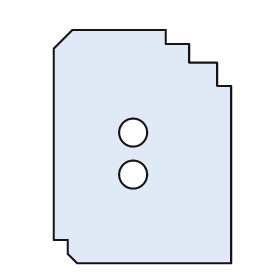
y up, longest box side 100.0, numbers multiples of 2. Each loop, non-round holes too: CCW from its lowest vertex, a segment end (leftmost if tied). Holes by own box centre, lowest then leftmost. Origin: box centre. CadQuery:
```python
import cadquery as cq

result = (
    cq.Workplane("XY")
    .moveTo(-28.0, -50.0)
    .lineTo(38.0, -50.0)
    .lineTo(38.0, 26.0)
    .lineTo(32.0, 26.0)
    .lineTo(32.0, 36.0)
    .lineTo(20.0, 36.0)
    .lineTo(20.0, 44.0)
    .lineTo(10.0, 44.0)
    .lineTo(10.0, 50.0)
    .lineTo(-30.0, 50.0)
    .lineTo(-38.0, 42.0)
    .lineTo(-38.0, -40.0)
    .lineTo(-32.0, -40.0)
    .lineTo(-32.0, -46.0)
    .close()
    .moveTo(-4.0, -12.0)
    .circle(6.0)
    .moveTo(-4.0, 6.0)
    .circle(6.0)
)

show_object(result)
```